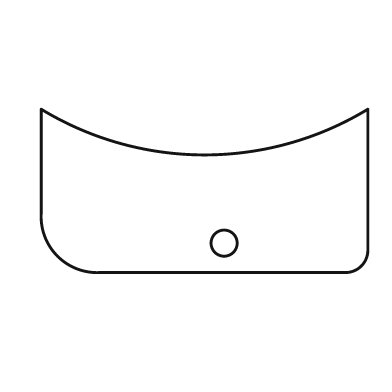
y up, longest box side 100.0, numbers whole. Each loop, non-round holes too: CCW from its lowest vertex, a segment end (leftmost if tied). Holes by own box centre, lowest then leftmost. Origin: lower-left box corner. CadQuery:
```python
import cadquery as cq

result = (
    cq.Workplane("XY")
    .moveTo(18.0, 0.0)
    .lineTo(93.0, 0.0)
    .threePointArc((98.0, 2.0), (100.0, 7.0))
    .lineTo(100.0, 50.0)
    .threePointArc((50.0, 36.0), (0.0, 50.0))
    .lineTo(0.0, 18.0)
    .threePointArc((5.0, 5.0), (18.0, 0.0))
    .close()
    .moveTo(56.0, 9.0)
    .circle(4.0)
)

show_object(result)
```